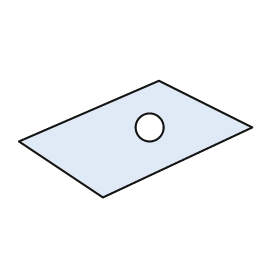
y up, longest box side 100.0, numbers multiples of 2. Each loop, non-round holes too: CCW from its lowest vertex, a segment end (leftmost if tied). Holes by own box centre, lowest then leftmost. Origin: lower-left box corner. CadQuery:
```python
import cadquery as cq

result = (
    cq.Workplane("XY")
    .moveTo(36.0, 0.0)
    .lineTo(100.0, 30.0)
    .lineTo(60.0, 50.0)
    .lineTo(0.0, 24.0)
    .close()
    .moveTo(56.0, 30.0)
    .circle(6.0)
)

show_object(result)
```